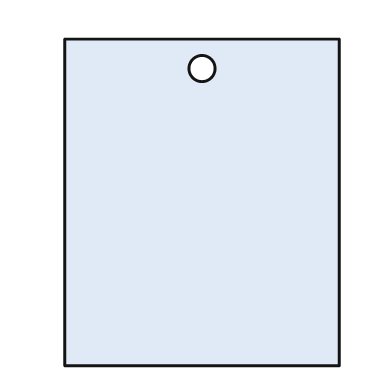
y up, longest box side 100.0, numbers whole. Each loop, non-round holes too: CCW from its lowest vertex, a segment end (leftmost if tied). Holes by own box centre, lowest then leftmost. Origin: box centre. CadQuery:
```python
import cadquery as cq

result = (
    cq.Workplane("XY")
    .moveTo(-42.0, -50.0)
    .lineTo(42.0, -50.0)
    .lineTo(42.0, 50.0)
    .lineTo(-42.0, 50.0)
    .close()
    .moveTo(0.0, 41.0)
    .circle(4.0)
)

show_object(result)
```